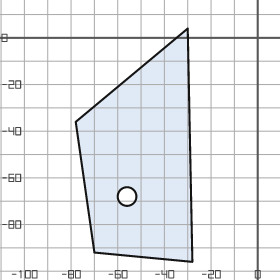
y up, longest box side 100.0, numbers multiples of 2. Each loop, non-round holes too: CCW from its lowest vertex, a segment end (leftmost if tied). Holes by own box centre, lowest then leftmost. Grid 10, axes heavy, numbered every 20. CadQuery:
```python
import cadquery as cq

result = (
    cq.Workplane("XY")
    .moveTo(-28.0, -96.0)
    .lineTo(-30.0, 4.0)
    .lineTo(-78.0, -36.0)
    .lineTo(-70.0, -92.0)
    .close()
    .moveTo(-56.0, -68.0)
    .circle(4.0)
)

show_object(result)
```